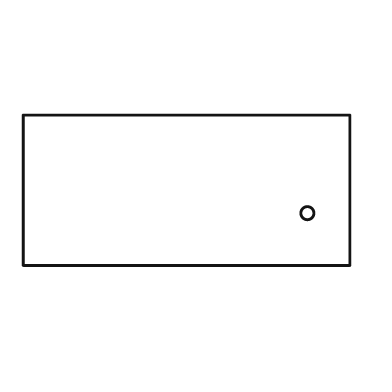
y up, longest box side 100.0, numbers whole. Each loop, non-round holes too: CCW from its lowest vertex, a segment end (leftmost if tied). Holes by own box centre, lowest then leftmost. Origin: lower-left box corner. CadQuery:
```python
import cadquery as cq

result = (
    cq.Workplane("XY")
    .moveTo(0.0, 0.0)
    .lineTo(100.0, 0.0)
    .lineTo(100.0, 46.0)
    .lineTo(0.0, 46.0)
    .close()
    .moveTo(87.0, 16.0)
    .circle(2.0)
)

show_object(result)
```